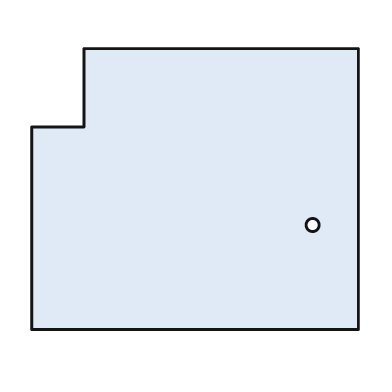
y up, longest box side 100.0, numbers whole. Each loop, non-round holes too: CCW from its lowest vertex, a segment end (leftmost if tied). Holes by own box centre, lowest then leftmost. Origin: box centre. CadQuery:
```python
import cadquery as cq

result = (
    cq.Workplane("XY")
    .moveTo(-50.0, -43.0)
    .lineTo(50.0, -43.0)
    .lineTo(50.0, 43.0)
    .lineTo(-34.0, 43.0)
    .lineTo(-34.0, 19.0)
    .lineTo(-50.0, 19.0)
    .close()
    .moveTo(36.0, -11.0)
    .circle(2.0)
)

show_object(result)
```